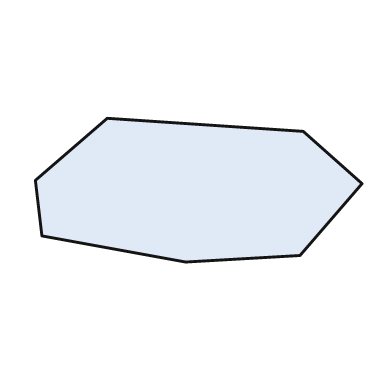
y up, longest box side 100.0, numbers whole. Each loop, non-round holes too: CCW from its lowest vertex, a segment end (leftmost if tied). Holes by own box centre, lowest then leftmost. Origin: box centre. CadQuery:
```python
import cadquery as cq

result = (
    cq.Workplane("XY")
    .moveTo(-4.0, -22.0)
    .lineTo(31.0, -20.0)
    .lineTo(50.0, 2.0)
    .lineTo(32.0, 18.0)
    .lineTo(-28.0, 22.0)
    .lineTo(-50.0, 3.0)
    .lineTo(-48.0, -14.0)
    .close()
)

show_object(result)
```